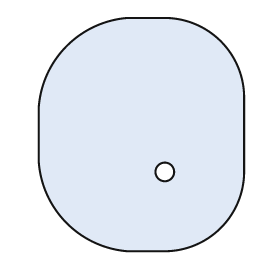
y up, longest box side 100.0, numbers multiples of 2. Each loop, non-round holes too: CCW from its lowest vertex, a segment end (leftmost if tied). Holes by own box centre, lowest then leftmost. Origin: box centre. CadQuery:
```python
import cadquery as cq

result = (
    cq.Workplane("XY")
    .moveTo(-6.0, -50.0)
    .lineTo(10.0, -50.0)
    .threePointArc((34.0, -40.0), (44.0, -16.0))
    .lineTo(44.0, 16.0)
    .threePointArc((34.0, 40.0), (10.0, 50.0))
    .lineTo(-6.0, 50.0)
    .threePointArc((-32.0, 38.0), (-44.0, 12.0))
    .lineTo(-44.0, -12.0)
    .threePointArc((-32.0, -38.0), (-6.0, -50.0))
    .close()
    .moveTo(10.0, -16.0)
    .circle(4.0)
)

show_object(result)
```